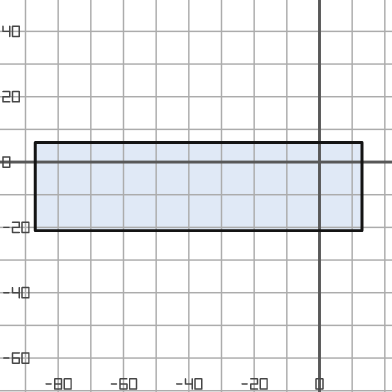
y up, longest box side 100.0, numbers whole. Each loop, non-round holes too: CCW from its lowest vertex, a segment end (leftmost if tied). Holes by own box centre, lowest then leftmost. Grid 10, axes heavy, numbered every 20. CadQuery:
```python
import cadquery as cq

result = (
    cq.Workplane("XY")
    .moveTo(-87.0, -21.0)
    .lineTo(13.0, -21.0)
    .lineTo(13.0, 6.0)
    .lineTo(-87.0, 6.0)
    .close()
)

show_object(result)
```